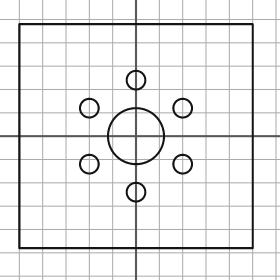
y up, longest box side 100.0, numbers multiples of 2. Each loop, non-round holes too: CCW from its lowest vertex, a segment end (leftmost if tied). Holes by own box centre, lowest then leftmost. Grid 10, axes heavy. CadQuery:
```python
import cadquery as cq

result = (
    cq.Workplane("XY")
    .moveTo(-50.0, -48.0)
    .lineTo(50.0, -48.0)
    .lineTo(50.0, 48.0)
    .lineTo(-50.0, 48.0)
    .close()
    .moveTo(0.0, -24.0)
    .circle(4.0)
    .moveTo(-20.0, -12.0)
    .circle(4.0)
    .moveTo(20.0, -12.0)
    .circle(4.0)
    .moveTo(0.0, 0.0)
    .circle(12.0)
    .moveTo(-20.0, 12.0)
    .circle(4.0)
    .moveTo(20.0, 12.0)
    .circle(4.0)
    .moveTo(0.0, 24.0)
    .circle(4.0)
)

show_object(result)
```